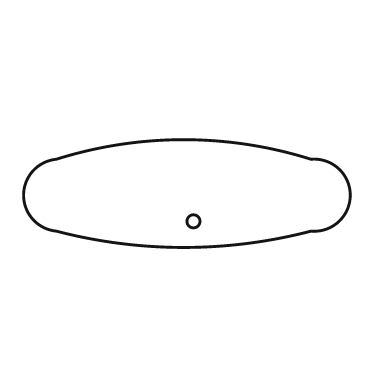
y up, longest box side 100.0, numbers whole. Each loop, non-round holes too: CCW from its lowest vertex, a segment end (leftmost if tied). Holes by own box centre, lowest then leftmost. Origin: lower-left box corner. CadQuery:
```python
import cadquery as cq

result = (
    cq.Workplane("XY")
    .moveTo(10.0, 5.0)
    .threePointArc((49.0, 0.0), (88.0, 5.0))
    .threePointArc((100.0, 16.0), (88.0, 27.0))
    .threePointArc((49.0, 33.0), (10.0, 27.0))
    .threePointArc((0.0, 16.0), (10.0, 5.0))
    .close()
    .moveTo(52.0, 8.0)
    .circle(2.0)
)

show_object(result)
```